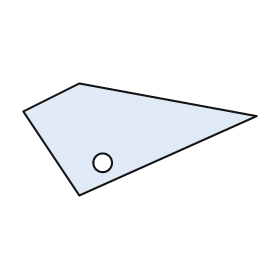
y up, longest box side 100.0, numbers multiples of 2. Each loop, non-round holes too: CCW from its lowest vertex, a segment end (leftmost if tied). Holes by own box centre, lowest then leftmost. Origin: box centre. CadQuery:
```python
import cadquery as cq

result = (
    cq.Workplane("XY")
    .moveTo(-26.0, -24.0)
    .lineTo(50.0, 10.0)
    .lineTo(-26.0, 24.0)
    .lineTo(-50.0, 12.0)
    .close()
    .moveTo(-16.0, -10.0)
    .circle(4.0)
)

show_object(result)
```